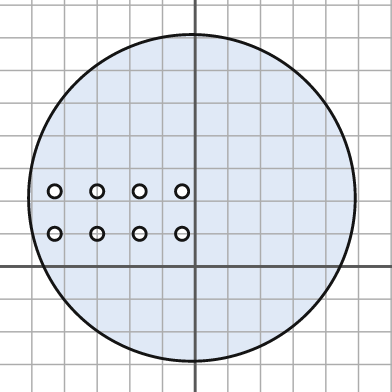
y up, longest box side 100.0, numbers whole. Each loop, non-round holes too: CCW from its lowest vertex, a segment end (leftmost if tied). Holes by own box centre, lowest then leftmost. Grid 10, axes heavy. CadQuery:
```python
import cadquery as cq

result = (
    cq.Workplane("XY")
    .moveTo(-1.0, 21.0)
    .circle(50.0)
    .moveTo(-43.0, 10.0)
    .circle(2.0)
    .moveTo(-30.0, 10.0)
    .circle(2.0)
    .moveTo(-17.0, 10.0)
    .circle(2.0)
    .moveTo(-4.0, 10.0)
    .circle(2.0)
    .moveTo(-43.0, 23.0)
    .circle(2.0)
    .moveTo(-30.0, 23.0)
    .circle(2.0)
    .moveTo(-17.0, 23.0)
    .circle(2.0)
    .moveTo(-4.0, 23.0)
    .circle(2.0)
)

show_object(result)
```